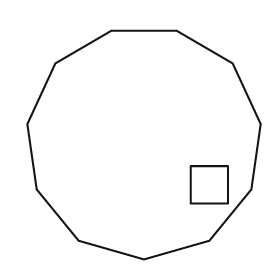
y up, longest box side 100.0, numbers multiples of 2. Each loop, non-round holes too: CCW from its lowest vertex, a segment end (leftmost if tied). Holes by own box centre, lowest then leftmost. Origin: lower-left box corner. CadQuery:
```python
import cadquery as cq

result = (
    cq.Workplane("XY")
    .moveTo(50.0, 0.0)
    .lineTo(78.0, 8.0)
    .lineTo(96.0, 30.0)
    .lineTo(100.0, 58.0)
    .lineTo(88.0, 84.0)
    .lineTo(64.0, 98.0)
    .lineTo(36.0, 98.0)
    .lineTo(12.0, 84.0)
    .lineTo(0.0, 58.0)
    .lineTo(4.0, 30.0)
    .lineTo(22.0, 8.0)
    .close()
    .moveTo(70.0, 24.0)
    .lineTo(86.0, 24.0)
    .lineTo(86.0, 40.0)
    .lineTo(70.0, 40.0)
    .close()
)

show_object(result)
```